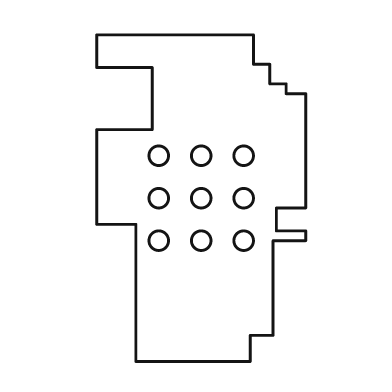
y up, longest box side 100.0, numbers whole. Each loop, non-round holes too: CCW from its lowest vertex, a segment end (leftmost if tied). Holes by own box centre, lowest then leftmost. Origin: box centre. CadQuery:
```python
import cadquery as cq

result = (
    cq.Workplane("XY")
    .moveTo(-20.0, -50.0)
    .lineTo(15.0, -50.0)
    .lineTo(15.0, -42.0)
    .lineTo(22.0, -42.0)
    .lineTo(22.0, -13.0)
    .lineTo(32.0, -13.0)
    .lineTo(32.0, -10.0)
    .lineTo(23.0, -10.0)
    .lineTo(23.0, -3.0)
    .lineTo(32.0, -3.0)
    .lineTo(32.0, 32.0)
    .lineTo(26.0, 32.0)
    .lineTo(26.0, 35.0)
    .lineTo(21.0, 35.0)
    .lineTo(21.0, 41.0)
    .lineTo(16.0, 41.0)
    .lineTo(16.0, 50.0)
    .lineTo(-32.0, 50.0)
    .lineTo(-32.0, 40.0)
    .lineTo(-15.0, 40.0)
    .lineTo(-15.0, 21.0)
    .lineTo(-32.0, 21.0)
    .lineTo(-32.0, -8.0)
    .lineTo(-20.0, -8.0)
    .close()
    .moveTo(-13.0, -13.0)
    .circle(3.0)
    .moveTo(0.0, -13.0)
    .circle(3.0)
    .moveTo(13.0, -13.0)
    .circle(3.0)
    .moveTo(-13.0, 0.0)
    .circle(3.0)
    .moveTo(0.0, 0.0)
    .circle(3.0)
    .moveTo(13.0, 0.0)
    .circle(3.0)
    .moveTo(-13.0, 13.0)
    .circle(3.0)
    .moveTo(0.0, 13.0)
    .circle(3.0)
    .moveTo(13.0, 13.0)
    .circle(3.0)
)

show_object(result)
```